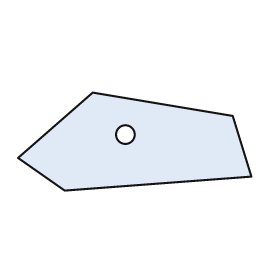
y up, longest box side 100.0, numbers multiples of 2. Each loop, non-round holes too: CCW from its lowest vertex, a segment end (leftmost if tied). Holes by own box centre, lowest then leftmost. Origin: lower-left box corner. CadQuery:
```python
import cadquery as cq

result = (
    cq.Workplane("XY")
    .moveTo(20.0, 0.0)
    .lineTo(100.0, 6.0)
    .lineTo(92.0, 32.0)
    .lineTo(32.0, 42.0)
    .lineTo(0.0, 14.0)
    .close()
    .moveTo(46.0, 24.0)
    .circle(4.0)
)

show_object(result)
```